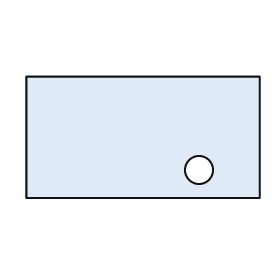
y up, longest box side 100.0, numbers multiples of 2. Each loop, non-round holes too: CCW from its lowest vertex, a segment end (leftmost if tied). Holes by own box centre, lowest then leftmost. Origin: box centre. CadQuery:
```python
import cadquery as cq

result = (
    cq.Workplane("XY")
    .moveTo(-50.0, -26.0)
    .lineTo(50.0, -26.0)
    .lineTo(50.0, 26.0)
    .lineTo(-50.0, 26.0)
    .close()
    .moveTo(24.0, -14.0)
    .circle(6.0)
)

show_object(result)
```